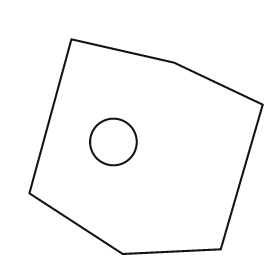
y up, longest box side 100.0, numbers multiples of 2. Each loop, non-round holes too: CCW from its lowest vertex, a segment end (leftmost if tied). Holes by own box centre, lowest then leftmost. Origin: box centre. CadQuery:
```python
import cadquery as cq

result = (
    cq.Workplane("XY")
    .moveTo(-10.0, -46.0)
    .lineTo(32.0, -44.0)
    .lineTo(50.0, 18.0)
    .lineTo(12.0, 36.0)
    .lineTo(-32.0, 46.0)
    .lineTo(-50.0, -20.0)
    .close()
    .moveTo(-14.0, 2.0)
    .circle(10.0)
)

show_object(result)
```